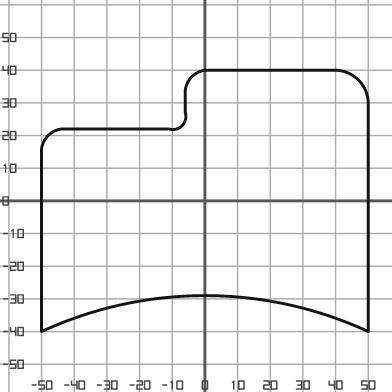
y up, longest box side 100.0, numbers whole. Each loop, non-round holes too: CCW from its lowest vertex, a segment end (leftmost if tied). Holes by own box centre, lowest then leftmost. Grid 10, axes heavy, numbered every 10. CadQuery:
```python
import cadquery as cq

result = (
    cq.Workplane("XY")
    .moveTo(-50.0, -40.0)
    .threePointArc((0.0, -29.0), (50.0, -40.0))
    .lineTo(50.0, 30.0)
    .threePointArc((47.0, 37.0), (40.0, 40.0))
    .lineTo(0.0, 40.0)
    .threePointArc((-4.0, 38.0), (-6.0, 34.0))
    .lineTo(-6.0, 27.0)
    .threePointArc((-7.0, 23.0), (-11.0, 22.0))
    .lineTo(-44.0, 22.0)
    .threePointArc((-48.0, 20.0), (-50.0, 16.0))
    .close()
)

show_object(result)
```